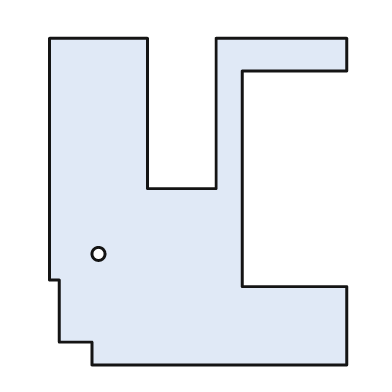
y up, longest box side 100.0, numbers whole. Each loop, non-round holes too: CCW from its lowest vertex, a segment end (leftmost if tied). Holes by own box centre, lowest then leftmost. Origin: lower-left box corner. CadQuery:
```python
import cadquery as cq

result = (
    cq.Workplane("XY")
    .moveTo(13.0, 0.0)
    .lineTo(91.0, 0.0)
    .lineTo(91.0, 24.0)
    .lineTo(59.0, 24.0)
    .lineTo(59.0, 90.0)
    .lineTo(91.0, 90.0)
    .lineTo(91.0, 100.0)
    .lineTo(51.0, 100.0)
    .lineTo(51.0, 54.0)
    .lineTo(30.0, 54.0)
    .lineTo(30.0, 100.0)
    .lineTo(0.0, 100.0)
    .lineTo(0.0, 26.0)
    .lineTo(3.0, 26.0)
    .lineTo(3.0, 7.0)
    .lineTo(13.0, 7.0)
    .close()
    .moveTo(15.0, 34.0)
    .circle(2.0)
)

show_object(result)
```